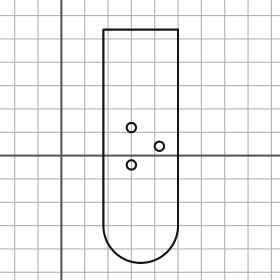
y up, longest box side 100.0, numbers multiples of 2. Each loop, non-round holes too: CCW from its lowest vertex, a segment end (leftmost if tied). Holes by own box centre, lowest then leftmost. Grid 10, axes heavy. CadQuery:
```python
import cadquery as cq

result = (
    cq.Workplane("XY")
    .moveTo(18.0, -30.0)
    .threePointArc((34.0, -46.0), (50.0, -30.0))
    .lineTo(50.0, 54.0)
    .lineTo(18.0, 54.0)
    .close()
    .moveTo(30.0, -4.0)
    .circle(2.0)
    .moveTo(42.0, 4.0)
    .circle(2.0)
    .moveTo(30.0, 12.0)
    .circle(2.0)
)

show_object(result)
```